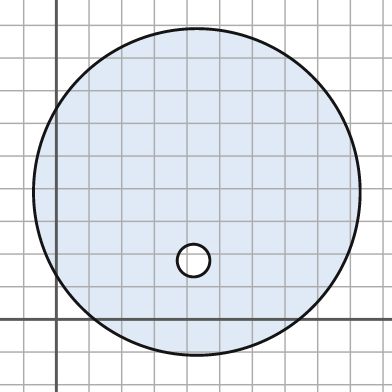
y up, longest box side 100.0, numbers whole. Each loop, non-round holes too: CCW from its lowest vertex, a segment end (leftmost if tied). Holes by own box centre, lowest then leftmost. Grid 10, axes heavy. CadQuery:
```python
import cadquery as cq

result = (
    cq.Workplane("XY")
    .moveTo(43.0, 39.0)
    .circle(50.0)
    .moveTo(42.0, 18.0)
    .circle(5.0)
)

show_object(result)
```